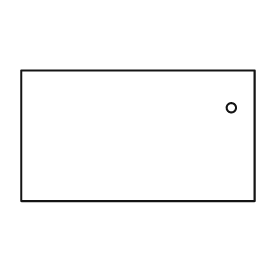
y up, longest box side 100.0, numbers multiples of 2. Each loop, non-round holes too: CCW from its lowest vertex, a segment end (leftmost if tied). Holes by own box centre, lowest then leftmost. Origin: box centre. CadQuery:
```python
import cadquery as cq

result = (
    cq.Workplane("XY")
    .moveTo(-50.0, -28.0)
    .lineTo(50.0, -28.0)
    .lineTo(50.0, 28.0)
    .lineTo(-50.0, 28.0)
    .close()
    .moveTo(40.0, 12.0)
    .circle(2.0)
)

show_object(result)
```